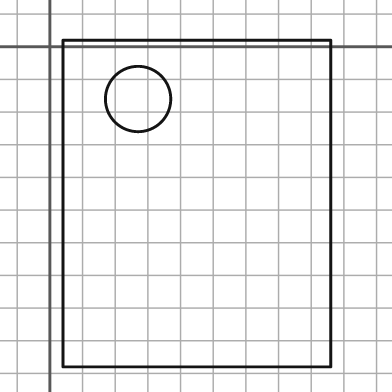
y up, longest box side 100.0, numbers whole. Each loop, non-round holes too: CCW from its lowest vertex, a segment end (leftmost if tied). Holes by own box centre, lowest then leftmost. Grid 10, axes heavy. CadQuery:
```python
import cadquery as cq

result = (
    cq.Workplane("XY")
    .moveTo(4.0, -98.0)
    .lineTo(86.0, -98.0)
    .lineTo(86.0, 2.0)
    .lineTo(4.0, 2.0)
    .close()
    .moveTo(27.0, -16.0)
    .circle(10.0)
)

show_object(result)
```